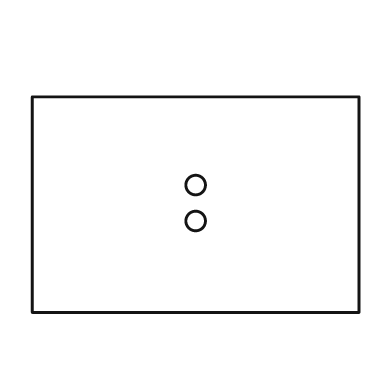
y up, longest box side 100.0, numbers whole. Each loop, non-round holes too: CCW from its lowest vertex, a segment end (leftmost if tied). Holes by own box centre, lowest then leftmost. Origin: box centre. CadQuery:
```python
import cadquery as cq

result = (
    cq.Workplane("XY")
    .moveTo(-50.0, -33.0)
    .lineTo(50.0, -33.0)
    .lineTo(50.0, 33.0)
    .lineTo(-50.0, 33.0)
    .close()
    .moveTo(0.0, -5.0)
    .circle(3.0)
    .moveTo(0.0, 6.0)
    .circle(3.0)
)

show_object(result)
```